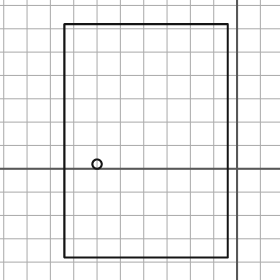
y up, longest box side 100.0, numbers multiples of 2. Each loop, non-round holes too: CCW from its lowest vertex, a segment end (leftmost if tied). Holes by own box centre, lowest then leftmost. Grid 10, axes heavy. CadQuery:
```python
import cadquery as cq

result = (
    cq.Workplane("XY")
    .moveTo(-74.0, -38.0)
    .lineTo(-4.0, -38.0)
    .lineTo(-4.0, 62.0)
    .lineTo(-74.0, 62.0)
    .close()
    .moveTo(-60.0, 2.0)
    .circle(2.0)
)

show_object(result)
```